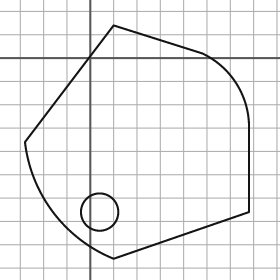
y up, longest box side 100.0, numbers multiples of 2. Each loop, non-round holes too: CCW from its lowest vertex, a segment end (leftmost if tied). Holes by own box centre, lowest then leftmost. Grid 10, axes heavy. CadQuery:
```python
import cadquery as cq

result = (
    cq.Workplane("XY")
    .moveTo(10.0, -86.0)
    .lineTo(68.0, -66.0)
    .lineTo(68.0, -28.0)
    .threePointArc((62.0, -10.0), (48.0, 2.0))
    .lineTo(10.0, 14.0)
    .lineTo(-28.0, -36.0)
    .threePointArc((-16.0, -66.0), (10.0, -86.0))
    .close()
    .moveTo(4.0, -66.0)
    .circle(8.0)
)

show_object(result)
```